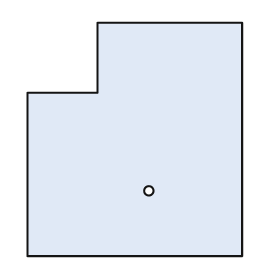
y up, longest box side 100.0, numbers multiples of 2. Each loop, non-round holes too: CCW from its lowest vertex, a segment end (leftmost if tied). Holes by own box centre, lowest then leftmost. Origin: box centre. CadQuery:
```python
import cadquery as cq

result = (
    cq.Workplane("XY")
    .moveTo(-46.0, -50.0)
    .lineTo(46.0, -50.0)
    .lineTo(46.0, 50.0)
    .lineTo(-16.0, 50.0)
    .lineTo(-16.0, 20.0)
    .lineTo(-46.0, 20.0)
    .close()
    .moveTo(6.0, -22.0)
    .circle(2.0)
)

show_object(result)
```